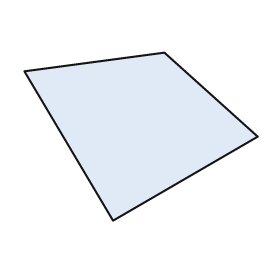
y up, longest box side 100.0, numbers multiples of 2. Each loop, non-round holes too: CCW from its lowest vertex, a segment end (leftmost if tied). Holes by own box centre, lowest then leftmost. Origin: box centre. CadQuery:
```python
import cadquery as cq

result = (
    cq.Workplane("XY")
    .moveTo(-12.0, -36.0)
    .lineTo(50.0, 0.0)
    .lineTo(10.0, 36.0)
    .lineTo(-50.0, 28.0)
    .close()
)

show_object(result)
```